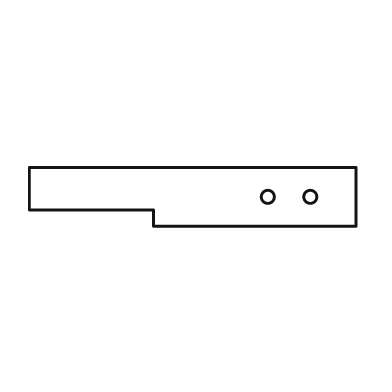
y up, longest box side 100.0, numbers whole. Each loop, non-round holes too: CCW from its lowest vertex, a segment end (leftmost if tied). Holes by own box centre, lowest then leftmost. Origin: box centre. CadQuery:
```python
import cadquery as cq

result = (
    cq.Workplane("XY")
    .moveTo(-12.0, -9.0)
    .lineTo(50.0, -9.0)
    .lineTo(50.0, 9.0)
    .lineTo(-50.0, 9.0)
    .lineTo(-50.0, -4.0)
    .lineTo(-12.0, -4.0)
    .close()
    .moveTo(23.0, 0.0)
    .circle(2.0)
    .moveTo(36.0, 0.0)
    .circle(2.0)
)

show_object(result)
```